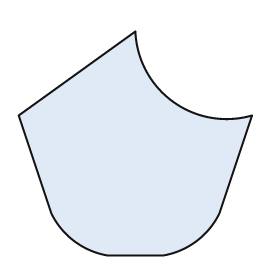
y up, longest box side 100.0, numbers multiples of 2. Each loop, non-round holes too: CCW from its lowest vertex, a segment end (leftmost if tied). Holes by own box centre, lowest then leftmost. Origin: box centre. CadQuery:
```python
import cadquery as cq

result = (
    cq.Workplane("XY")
    .moveTo(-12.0, -48.0)
    .lineTo(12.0, -48.0)
    .threePointArc((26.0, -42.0), (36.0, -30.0))
    .lineTo(50.0, 12.0)
    .threePointArc((16.0, 18.0), (0.0, 48.0))
    .lineTo(-50.0, 12.0)
    .lineTo(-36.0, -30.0)
    .threePointArc((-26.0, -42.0), (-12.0, -48.0))
    .close()
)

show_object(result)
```